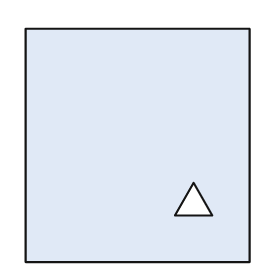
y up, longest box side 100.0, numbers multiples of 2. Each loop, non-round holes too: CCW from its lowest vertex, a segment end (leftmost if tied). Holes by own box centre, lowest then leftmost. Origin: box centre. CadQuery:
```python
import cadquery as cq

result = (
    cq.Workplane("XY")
    .moveTo(-48.0, -50.0)
    .lineTo(48.0, -50.0)
    .lineTo(48.0, 50.0)
    .lineTo(-48.0, 50.0)
    .close()
    .moveTo(16.0, -30.0)
    .lineTo(32.0, -30.0)
    .lineTo(24.0, -16.0)
    .close()
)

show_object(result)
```